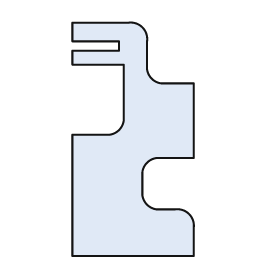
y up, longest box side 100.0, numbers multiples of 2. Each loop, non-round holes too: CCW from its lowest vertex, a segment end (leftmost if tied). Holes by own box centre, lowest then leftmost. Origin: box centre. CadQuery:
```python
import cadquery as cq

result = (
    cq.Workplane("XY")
    .moveTo(-26.0, -50.0)
    .lineTo(26.0, -50.0)
    .lineTo(26.0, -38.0)
    .threePointArc((24.0, -32.0), (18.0, -30.0))
    .lineTo(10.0, -30.0)
    .threePointArc((6.0, -28.0), (4.0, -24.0))
    .lineTo(4.0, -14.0)
    .threePointArc((6.0, -10.0), (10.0, -8.0))
    .lineTo(26.0, -8.0)
    .lineTo(26.0, 24.0)
    .lineTo(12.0, 24.0)
    .threePointArc((8.0, 26.0), (6.0, 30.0))
    .lineTo(6.0, 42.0)
    .threePointArc((4.0, 48.0), (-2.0, 50.0))
    .lineTo(-26.0, 50.0)
    .lineTo(-26.0, 42.0)
    .lineTo(-6.0, 42.0)
    .lineTo(-6.0, 38.0)
    .lineTo(-26.0, 38.0)
    .lineTo(-26.0, 32.0)
    .lineTo(-4.0, 32.0)
    .lineTo(-4.0, 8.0)
    .threePointArc((-6.0, 4.0), (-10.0, 2.0))
    .lineTo(-26.0, 2.0)
    .close()
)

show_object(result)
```